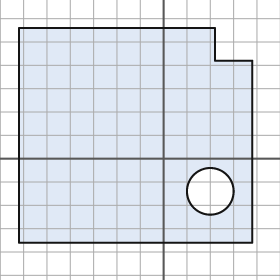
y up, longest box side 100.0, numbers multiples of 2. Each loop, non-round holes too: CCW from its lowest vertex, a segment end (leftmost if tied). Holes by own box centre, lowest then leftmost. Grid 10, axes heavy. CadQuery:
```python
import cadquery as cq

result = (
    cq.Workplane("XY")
    .moveTo(-62.0, -36.0)
    .lineTo(38.0, -36.0)
    .lineTo(38.0, 42.0)
    .lineTo(22.0, 42.0)
    .lineTo(22.0, 56.0)
    .lineTo(-62.0, 56.0)
    .close()
    .moveTo(20.0, -14.0)
    .circle(10.0)
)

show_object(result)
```